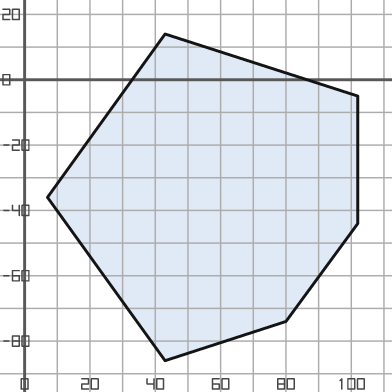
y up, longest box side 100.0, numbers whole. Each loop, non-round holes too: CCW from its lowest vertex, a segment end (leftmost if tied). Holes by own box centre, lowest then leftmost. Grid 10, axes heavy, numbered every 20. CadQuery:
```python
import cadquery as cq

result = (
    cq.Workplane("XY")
    .moveTo(43.0, -86.0)
    .lineTo(80.0, -74.0)
    .lineTo(102.0, -44.0)
    .lineTo(102.0, -5.0)
    .lineTo(43.0, 14.0)
    .lineTo(7.0, -36.0)
    .close()
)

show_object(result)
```